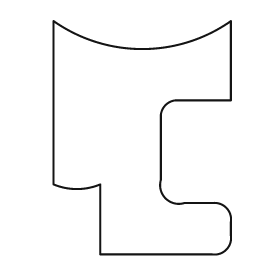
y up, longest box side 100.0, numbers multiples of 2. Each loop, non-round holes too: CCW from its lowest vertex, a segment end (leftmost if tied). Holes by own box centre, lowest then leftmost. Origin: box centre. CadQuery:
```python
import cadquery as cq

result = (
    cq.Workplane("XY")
    .moveTo(-18.0, -50.0)
    .lineTo(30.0, -50.0)
    .threePointArc((36.0, -48.0), (38.0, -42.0))
    .lineTo(38.0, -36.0)
    .threePointArc((36.0, -30.0), (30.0, -28.0))
    .lineTo(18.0, -28.0)
    .threePointArc((10.0, -26.0), (8.0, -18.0))
    .lineTo(8.0, 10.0)
    .threePointArc((10.0, 14.0), (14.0, 16.0))
    .lineTo(38.0, 16.0)
    .lineTo(38.0, 50.0)
    .threePointArc((0.0, 38.0), (-38.0, 50.0))
    .lineTo(-38.0, -20.0)
    .threePointArc((-28.0, -22.0), (-18.0, -20.0))
    .close()
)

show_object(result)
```